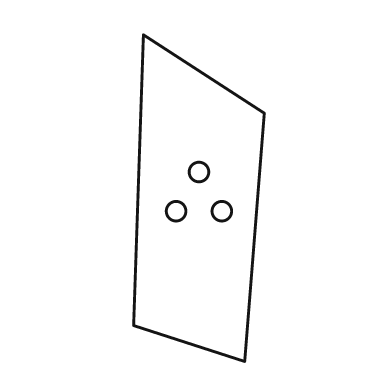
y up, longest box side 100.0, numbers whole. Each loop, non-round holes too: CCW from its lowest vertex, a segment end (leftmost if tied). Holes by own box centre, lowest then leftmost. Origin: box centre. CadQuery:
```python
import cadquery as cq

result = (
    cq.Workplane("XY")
    .moveTo(14.0, -50.0)
    .lineTo(20.0, 26.0)
    .lineTo(-17.0, 50.0)
    .lineTo(-20.0, -39.0)
    .close()
    .moveTo(-7.0, -4.0)
    .circle(3.0)
    .moveTo(7.0, -4.0)
    .circle(3.0)
    .moveTo(0.0, 8.0)
    .circle(3.0)
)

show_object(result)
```